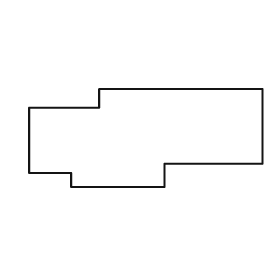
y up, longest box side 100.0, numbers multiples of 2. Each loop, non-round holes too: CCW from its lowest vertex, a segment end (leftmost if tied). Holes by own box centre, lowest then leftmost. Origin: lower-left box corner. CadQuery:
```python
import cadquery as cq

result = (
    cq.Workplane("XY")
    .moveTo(18.0, 0.0)
    .lineTo(58.0, 0.0)
    .lineTo(58.0, 10.0)
    .lineTo(100.0, 10.0)
    .lineTo(100.0, 42.0)
    .lineTo(30.0, 42.0)
    .lineTo(30.0, 34.0)
    .lineTo(0.0, 34.0)
    .lineTo(0.0, 6.0)
    .lineTo(18.0, 6.0)
    .close()
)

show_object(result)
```